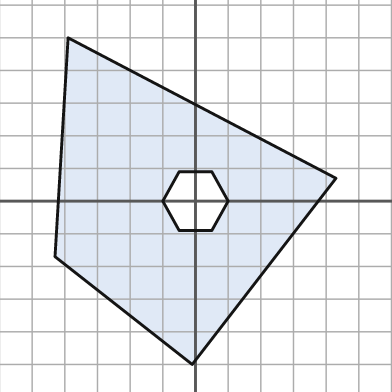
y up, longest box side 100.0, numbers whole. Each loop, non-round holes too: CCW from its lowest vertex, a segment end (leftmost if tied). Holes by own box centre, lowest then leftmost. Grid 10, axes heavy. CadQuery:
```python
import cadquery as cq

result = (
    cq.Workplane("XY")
    .moveTo(-1.0, -50.0)
    .lineTo(43.0, 7.0)
    .lineTo(-39.0, 50.0)
    .lineTo(-43.0, -17.0)
    .close()
    .moveTo(-5.0, -9.0)
    .lineTo(5.0, -9.0)
    .lineTo(10.0, 0.0)
    .lineTo(5.0, 9.0)
    .lineTo(-5.0, 9.0)
    .lineTo(-10.0, 0.0)
    .close()
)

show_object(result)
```